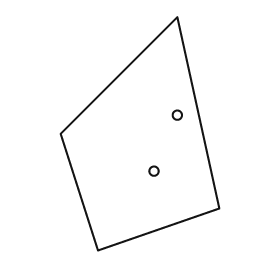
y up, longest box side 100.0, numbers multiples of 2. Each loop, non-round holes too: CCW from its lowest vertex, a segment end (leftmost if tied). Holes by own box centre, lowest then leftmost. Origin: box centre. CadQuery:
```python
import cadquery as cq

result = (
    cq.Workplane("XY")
    .moveTo(-18.0, -50.0)
    .lineTo(34.0, -32.0)
    .lineTo(16.0, 50.0)
    .lineTo(-34.0, 0.0)
    .close()
    .moveTo(6.0, -16.0)
    .circle(2.0)
    .moveTo(16.0, 8.0)
    .circle(2.0)
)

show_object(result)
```